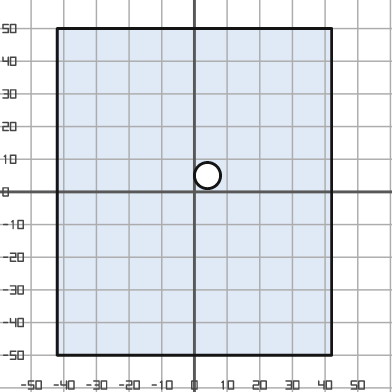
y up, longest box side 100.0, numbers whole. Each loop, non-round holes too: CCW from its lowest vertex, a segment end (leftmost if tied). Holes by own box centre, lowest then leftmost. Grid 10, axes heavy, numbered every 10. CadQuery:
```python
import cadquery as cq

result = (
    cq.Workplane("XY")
    .moveTo(-42.0, -50.0)
    .lineTo(42.0, -50.0)
    .lineTo(42.0, 50.0)
    .lineTo(-42.0, 50.0)
    .close()
    .moveTo(4.0, 5.0)
    .circle(4.0)
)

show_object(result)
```